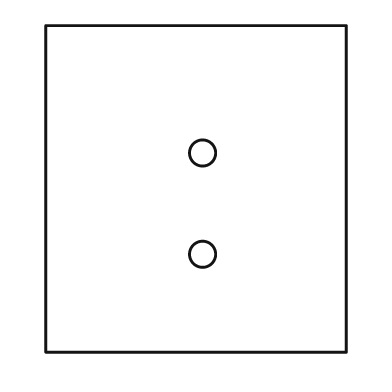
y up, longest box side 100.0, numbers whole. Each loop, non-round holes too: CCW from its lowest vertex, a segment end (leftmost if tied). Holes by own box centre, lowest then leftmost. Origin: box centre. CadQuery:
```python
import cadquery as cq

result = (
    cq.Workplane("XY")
    .moveTo(-46.0, -50.0)
    .lineTo(46.0, -50.0)
    .lineTo(46.0, 50.0)
    .lineTo(-46.0, 50.0)
    .close()
    .moveTo(2.0, -20.0)
    .circle(4.0)
    .moveTo(2.0, 11.0)
    .circle(4.0)
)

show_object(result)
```